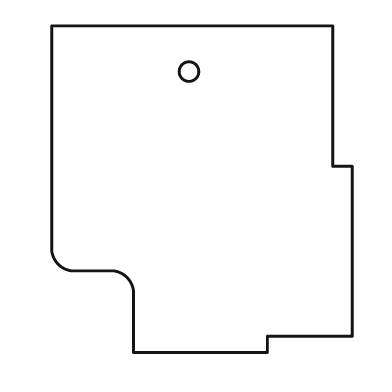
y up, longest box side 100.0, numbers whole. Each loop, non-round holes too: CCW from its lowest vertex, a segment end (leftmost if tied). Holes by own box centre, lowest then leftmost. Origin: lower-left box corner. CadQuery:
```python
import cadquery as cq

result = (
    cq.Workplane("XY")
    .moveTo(25.0, 0.0)
    .lineTo(66.0, 0.0)
    .lineTo(66.0, 5.0)
    .lineTo(92.0, 5.0)
    .lineTo(92.0, 57.0)
    .lineTo(86.0, 57.0)
    .lineTo(86.0, 100.0)
    .lineTo(0.0, 100.0)
    .lineTo(0.0, 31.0)
    .threePointArc((2.0, 27.0), (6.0, 25.0))
    .lineTo(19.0, 25.0)
    .threePointArc((23.0, 23.0), (25.0, 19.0))
    .close()
    .moveTo(42.0, 86.0)
    .circle(3.0)
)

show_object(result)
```